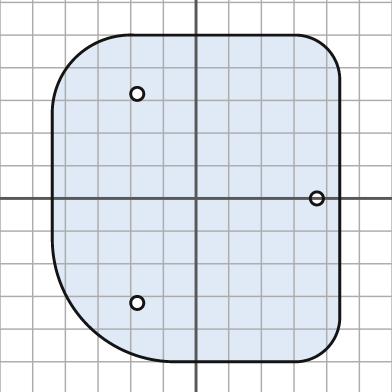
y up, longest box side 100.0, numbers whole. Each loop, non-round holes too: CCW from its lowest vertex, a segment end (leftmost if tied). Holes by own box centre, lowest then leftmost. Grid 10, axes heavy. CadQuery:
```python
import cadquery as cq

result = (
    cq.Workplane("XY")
    .moveTo(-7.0, -50.0)
    .lineTo(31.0, -50.0)
    .threePointArc((40.0, -46.0), (44.0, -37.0))
    .lineTo(44.0, 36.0)
    .threePointArc((40.0, 46.0), (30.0, 50.0))
    .lineTo(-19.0, 50.0)
    .threePointArc((-37.0, 43.0), (-44.0, 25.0))
    .lineTo(-44.0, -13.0)
    .threePointArc((-33.0, -39.0), (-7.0, -50.0))
    .close()
    .moveTo(-18.0, -32.0)
    .circle(2.0)
    .moveTo(37.0, 0.0)
    .circle(2.0)
    .moveTo(-18.0, 32.0)
    .circle(2.0)
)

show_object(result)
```